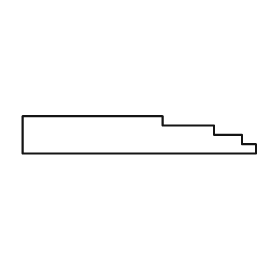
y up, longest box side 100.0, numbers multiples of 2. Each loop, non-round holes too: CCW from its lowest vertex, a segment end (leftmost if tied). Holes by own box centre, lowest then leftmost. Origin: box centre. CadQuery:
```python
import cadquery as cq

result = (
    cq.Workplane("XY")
    .moveTo(-50.0, -8.0)
    .lineTo(50.0, -8.0)
    .lineTo(50.0, -4.0)
    .lineTo(44.0, -4.0)
    .lineTo(44.0, 0.0)
    .lineTo(32.0, 0.0)
    .lineTo(32.0, 4.0)
    .lineTo(10.0, 4.0)
    .lineTo(10.0, 8.0)
    .lineTo(-50.0, 8.0)
    .close()
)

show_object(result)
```